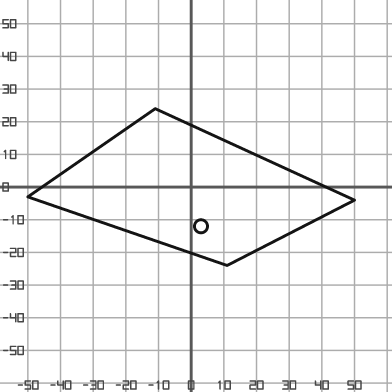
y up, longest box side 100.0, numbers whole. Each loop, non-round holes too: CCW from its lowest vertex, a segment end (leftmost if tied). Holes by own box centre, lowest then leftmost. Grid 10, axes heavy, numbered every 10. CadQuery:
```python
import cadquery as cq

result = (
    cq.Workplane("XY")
    .moveTo(11.0, -24.0)
    .lineTo(50.0, -4.0)
    .lineTo(-11.0, 24.0)
    .lineTo(-50.0, -3.0)
    .close()
    .moveTo(3.0, -12.0)
    .circle(2.0)
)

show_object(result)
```